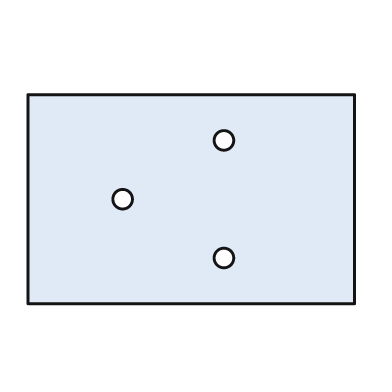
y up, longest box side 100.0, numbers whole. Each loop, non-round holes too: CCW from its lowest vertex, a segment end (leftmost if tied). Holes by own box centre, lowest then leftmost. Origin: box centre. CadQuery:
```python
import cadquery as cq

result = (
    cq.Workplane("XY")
    .moveTo(-50.0, -32.0)
    .lineTo(50.0, -32.0)
    .lineTo(50.0, 32.0)
    .lineTo(-50.0, 32.0)
    .close()
    .moveTo(10.0, -18.0)
    .circle(3.0)
    .moveTo(-21.0, 0.0)
    .circle(3.0)
    .moveTo(10.0, 18.0)
    .circle(3.0)
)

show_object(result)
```